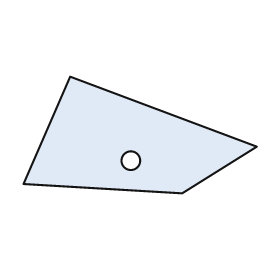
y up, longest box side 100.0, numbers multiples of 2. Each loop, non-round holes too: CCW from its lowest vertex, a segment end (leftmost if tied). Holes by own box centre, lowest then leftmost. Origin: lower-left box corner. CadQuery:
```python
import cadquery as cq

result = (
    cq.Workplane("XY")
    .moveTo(68.0, 0.0)
    .lineTo(100.0, 20.0)
    .lineTo(20.0, 50.0)
    .lineTo(0.0, 4.0)
    .close()
    .moveTo(46.0, 14.0)
    .circle(4.0)
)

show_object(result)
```